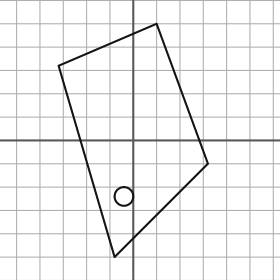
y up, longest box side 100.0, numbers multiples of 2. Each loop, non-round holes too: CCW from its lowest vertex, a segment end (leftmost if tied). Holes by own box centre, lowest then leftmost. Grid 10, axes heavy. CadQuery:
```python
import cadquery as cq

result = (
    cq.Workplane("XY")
    .moveTo(-8.0, -50.0)
    .lineTo(32.0, -10.0)
    .lineTo(10.0, 50.0)
    .lineTo(-32.0, 32.0)
    .close()
    .moveTo(-4.0, -24.0)
    .circle(4.0)
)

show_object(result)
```